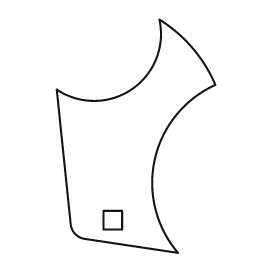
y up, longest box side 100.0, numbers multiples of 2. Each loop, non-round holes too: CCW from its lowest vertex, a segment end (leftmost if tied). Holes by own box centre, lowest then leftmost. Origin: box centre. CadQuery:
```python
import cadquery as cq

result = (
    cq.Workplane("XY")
    .moveTo(18.0, -50.0)
    .threePointArc((8.0, -10.0), (34.0, 22.0))
    .threePointArc((24.0, 38.0), (10.0, 50.0))
    .threePointArc((-2.0, 20.0), (-34.0, 20.0))
    .lineTo(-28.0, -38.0)
    .threePointArc((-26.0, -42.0), (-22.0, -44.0))
    .close()
    .moveTo(-14.0, -40.0)
    .lineTo(-6.0, -40.0)
    .lineTo(-6.0, -32.0)
    .lineTo(-14.0, -32.0)
    .close()
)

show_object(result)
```